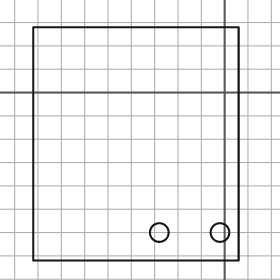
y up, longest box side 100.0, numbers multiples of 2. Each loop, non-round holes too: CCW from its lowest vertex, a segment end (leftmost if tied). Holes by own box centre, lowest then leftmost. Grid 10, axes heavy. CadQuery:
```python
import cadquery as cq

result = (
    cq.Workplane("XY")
    .moveTo(-82.0, -72.0)
    .lineTo(6.0, -72.0)
    .lineTo(6.0, 28.0)
    .lineTo(-82.0, 28.0)
    .close()
    .moveTo(-28.0, -60.0)
    .circle(4.0)
    .moveTo(-2.0, -60.0)
    .circle(4.0)
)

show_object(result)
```